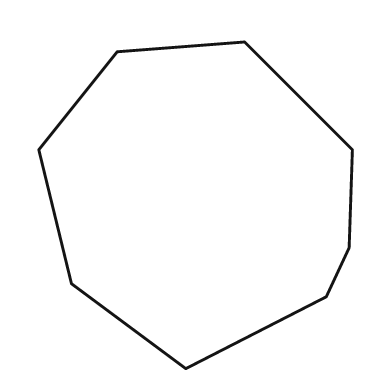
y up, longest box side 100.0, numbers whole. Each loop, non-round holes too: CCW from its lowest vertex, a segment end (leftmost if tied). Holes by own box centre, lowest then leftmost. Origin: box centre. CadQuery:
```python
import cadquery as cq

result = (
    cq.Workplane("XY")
    .moveTo(-3.0, -50.0)
    .lineTo(40.0, -28.0)
    .lineTo(47.0, -13.0)
    .lineTo(48.0, 17.0)
    .lineTo(15.0, 50.0)
    .lineTo(-24.0, 47.0)
    .lineTo(-48.0, 17.0)
    .lineTo(-38.0, -24.0)
    .close()
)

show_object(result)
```